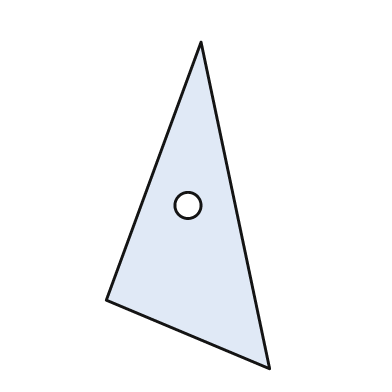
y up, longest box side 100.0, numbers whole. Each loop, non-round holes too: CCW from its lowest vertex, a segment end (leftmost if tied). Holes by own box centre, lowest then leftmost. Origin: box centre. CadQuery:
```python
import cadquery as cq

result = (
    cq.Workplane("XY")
    .moveTo(25.0, -50.0)
    .lineTo(4.0, 50.0)
    .lineTo(-25.0, -29.0)
    .close()
    .moveTo(0.0, 0.0)
    .circle(4.0)
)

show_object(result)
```